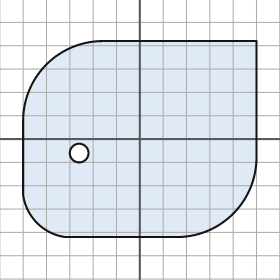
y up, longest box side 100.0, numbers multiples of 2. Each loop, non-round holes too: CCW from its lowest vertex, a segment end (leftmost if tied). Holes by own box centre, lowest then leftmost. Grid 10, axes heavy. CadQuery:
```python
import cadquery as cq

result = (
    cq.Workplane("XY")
    .moveTo(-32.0, -42.0)
    .lineTo(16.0, -42.0)
    .threePointArc((40.0, -32.0), (50.0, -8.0))
    .lineTo(50.0, 42.0)
    .lineTo(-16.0, 42.0)
    .threePointArc((-40.0, 32.0), (-50.0, 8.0))
    .lineTo(-50.0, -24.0)
    .threePointArc((-44.0, -36.0), (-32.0, -42.0))
    .close()
    .moveTo(-26.0, -6.0)
    .circle(4.0)
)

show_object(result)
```